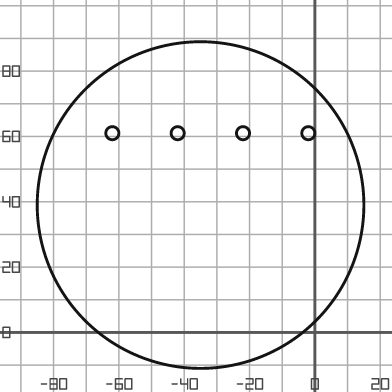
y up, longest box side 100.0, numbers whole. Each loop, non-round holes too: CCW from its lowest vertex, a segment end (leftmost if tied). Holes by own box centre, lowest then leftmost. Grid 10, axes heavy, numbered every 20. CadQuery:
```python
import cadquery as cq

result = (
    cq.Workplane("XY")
    .moveTo(-35.0, 39.0)
    .circle(50.0)
    .moveTo(-62.0, 61.0)
    .circle(2.0)
    .moveTo(-42.0, 61.0)
    .circle(2.0)
    .moveTo(-22.0, 61.0)
    .circle(2.0)
    .moveTo(-2.0, 61.0)
    .circle(2.0)
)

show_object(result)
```